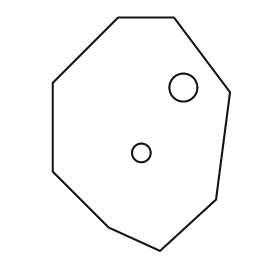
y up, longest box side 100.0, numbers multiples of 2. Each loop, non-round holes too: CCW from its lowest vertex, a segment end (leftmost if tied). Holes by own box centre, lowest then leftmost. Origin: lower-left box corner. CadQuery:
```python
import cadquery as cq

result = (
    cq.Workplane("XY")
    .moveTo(46.0, 0.0)
    .lineTo(70.0, 22.0)
    .lineTo(76.0, 68.0)
    .lineTo(52.0, 100.0)
    .lineTo(28.0, 100.0)
    .lineTo(0.0, 72.0)
    .lineTo(0.0, 34.0)
    .lineTo(24.0, 10.0)
    .close()
    .moveTo(38.0, 42.0)
    .circle(4.0)
    .moveTo(56.0, 70.0)
    .circle(6.0)
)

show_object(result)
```